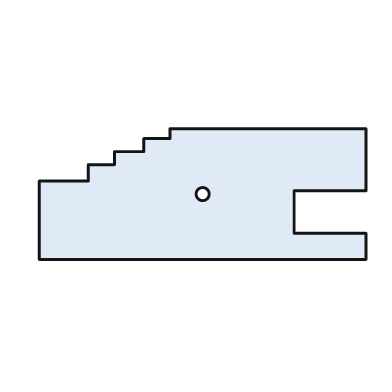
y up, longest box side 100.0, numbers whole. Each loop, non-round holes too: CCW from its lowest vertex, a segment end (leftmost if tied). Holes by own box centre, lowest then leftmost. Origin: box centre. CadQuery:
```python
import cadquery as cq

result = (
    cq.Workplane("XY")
    .moveTo(-50.0, -20.0)
    .lineTo(50.0, -20.0)
    .lineTo(50.0, -12.0)
    .lineTo(28.0, -12.0)
    .lineTo(28.0, 1.0)
    .lineTo(50.0, 1.0)
    .lineTo(50.0, 20.0)
    .lineTo(-10.0, 20.0)
    .lineTo(-10.0, 17.0)
    .lineTo(-18.0, 17.0)
    .lineTo(-18.0, 13.0)
    .lineTo(-27.0, 13.0)
    .lineTo(-27.0, 9.0)
    .lineTo(-35.0, 9.0)
    .lineTo(-35.0, 4.0)
    .lineTo(-50.0, 4.0)
    .close()
    .moveTo(0.0, 0.0)
    .circle(2.0)
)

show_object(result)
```